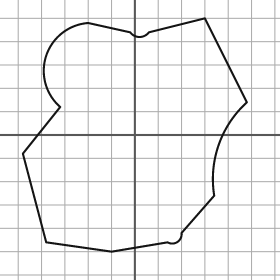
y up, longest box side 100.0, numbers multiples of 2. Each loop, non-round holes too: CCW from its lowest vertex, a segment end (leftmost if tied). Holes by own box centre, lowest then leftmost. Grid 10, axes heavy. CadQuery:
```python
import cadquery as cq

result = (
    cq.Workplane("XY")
    .moveTo(-10.0, -50.0)
    .lineTo(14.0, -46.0)
    .threePointArc((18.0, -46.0), (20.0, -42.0))
    .lineTo(34.0, -26.0)
    .threePointArc((36.0, -4.0), (48.0, 14.0))
    .lineTo(30.0, 50.0)
    .lineTo(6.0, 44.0)
    .threePointArc((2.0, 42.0), (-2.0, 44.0))
    .lineTo(-20.0, 48.0)
    .threePointArc((-38.0, 34.0), (-32.0, 12.0))
    .lineTo(-48.0, -8.0)
    .lineTo(-38.0, -46.0)
    .close()
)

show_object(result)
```